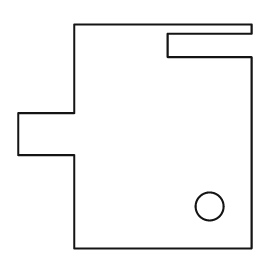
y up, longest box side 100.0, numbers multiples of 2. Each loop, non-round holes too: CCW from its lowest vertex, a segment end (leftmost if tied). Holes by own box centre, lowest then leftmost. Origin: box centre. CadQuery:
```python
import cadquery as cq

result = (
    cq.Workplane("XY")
    .moveTo(-26.0, -48.0)
    .lineTo(50.0, -48.0)
    .lineTo(50.0, 34.0)
    .lineTo(14.0, 34.0)
    .lineTo(14.0, 44.0)
    .lineTo(50.0, 44.0)
    .lineTo(50.0, 48.0)
    .lineTo(-26.0, 48.0)
    .lineTo(-26.0, 10.0)
    .lineTo(-50.0, 10.0)
    .lineTo(-50.0, -8.0)
    .lineTo(-26.0, -8.0)
    .close()
    .moveTo(32.0, -30.0)
    .circle(6.0)
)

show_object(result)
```